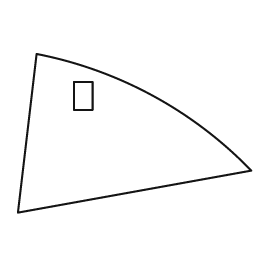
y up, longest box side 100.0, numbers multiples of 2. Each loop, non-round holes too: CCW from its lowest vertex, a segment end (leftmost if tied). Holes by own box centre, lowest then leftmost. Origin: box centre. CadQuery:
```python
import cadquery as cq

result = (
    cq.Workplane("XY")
    .moveTo(-50.0, -34.0)
    .lineTo(50.0, -16.0)
    .threePointArc((8.0, 16.0), (-42.0, 34.0))
    .close()
    .moveTo(-26.0, 10.0)
    .lineTo(-18.0, 10.0)
    .lineTo(-18.0, 22.0)
    .lineTo(-26.0, 22.0)
    .close()
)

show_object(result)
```